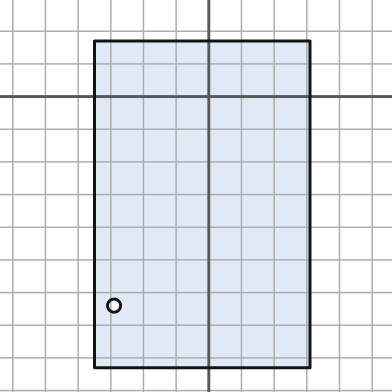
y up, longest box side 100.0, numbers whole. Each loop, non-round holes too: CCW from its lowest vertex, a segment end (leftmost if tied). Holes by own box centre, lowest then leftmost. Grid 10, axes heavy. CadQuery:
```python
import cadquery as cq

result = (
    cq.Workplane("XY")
    .moveTo(-35.0, -83.0)
    .lineTo(31.0, -83.0)
    .lineTo(31.0, 17.0)
    .lineTo(-35.0, 17.0)
    .close()
    .moveTo(-29.0, -64.0)
    .circle(2.0)
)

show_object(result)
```